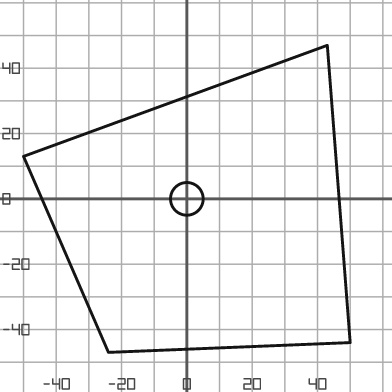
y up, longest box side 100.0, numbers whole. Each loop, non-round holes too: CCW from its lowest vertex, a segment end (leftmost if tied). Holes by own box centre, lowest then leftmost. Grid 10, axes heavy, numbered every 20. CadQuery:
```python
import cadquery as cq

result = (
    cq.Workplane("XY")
    .moveTo(-24.0, -47.0)
    .lineTo(50.0, -44.0)
    .lineTo(43.0, 47.0)
    .lineTo(-50.0, 13.0)
    .close()
    .moveTo(0.0, 0.0)
    .circle(5.0)
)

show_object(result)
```